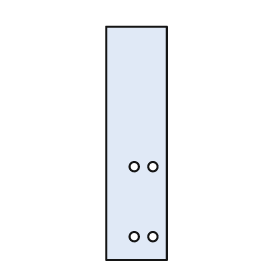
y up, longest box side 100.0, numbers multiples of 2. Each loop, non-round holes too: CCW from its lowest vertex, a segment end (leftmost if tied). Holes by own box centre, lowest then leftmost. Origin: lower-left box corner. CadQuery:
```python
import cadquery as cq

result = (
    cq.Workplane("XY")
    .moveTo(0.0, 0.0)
    .lineTo(26.0, 0.0)
    .lineTo(26.0, 100.0)
    .lineTo(0.0, 100.0)
    .close()
    .moveTo(12.0, 10.0)
    .circle(2.0)
    .moveTo(20.0, 10.0)
    .circle(2.0)
    .moveTo(12.0, 40.0)
    .circle(2.0)
    .moveTo(20.0, 40.0)
    .circle(2.0)
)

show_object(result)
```